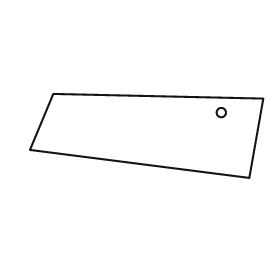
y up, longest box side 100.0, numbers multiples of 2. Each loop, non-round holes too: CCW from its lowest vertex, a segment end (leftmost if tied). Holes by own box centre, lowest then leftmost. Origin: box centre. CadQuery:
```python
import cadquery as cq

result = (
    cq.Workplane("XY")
    .moveTo(44.0, -18.0)
    .lineTo(50.0, 16.0)
    .lineTo(-40.0, 18.0)
    .lineTo(-50.0, -6.0)
    .close()
    .moveTo(32.0, 10.0)
    .circle(2.0)
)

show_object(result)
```